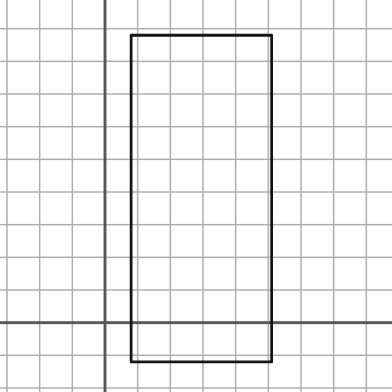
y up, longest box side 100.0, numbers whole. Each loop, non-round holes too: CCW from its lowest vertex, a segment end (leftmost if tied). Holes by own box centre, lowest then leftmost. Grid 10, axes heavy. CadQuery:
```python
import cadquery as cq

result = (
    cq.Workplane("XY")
    .moveTo(8.0, -12.0)
    .lineTo(51.0, -12.0)
    .lineTo(51.0, 88.0)
    .lineTo(8.0, 88.0)
    .close()
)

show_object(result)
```